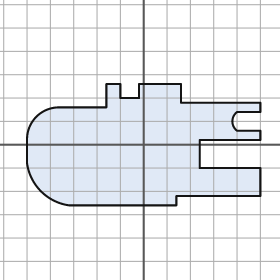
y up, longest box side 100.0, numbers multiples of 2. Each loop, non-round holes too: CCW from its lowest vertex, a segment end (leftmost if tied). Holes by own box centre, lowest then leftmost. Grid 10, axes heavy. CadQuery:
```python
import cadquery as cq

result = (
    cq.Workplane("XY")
    .moveTo(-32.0, -26.0)
    .lineTo(14.0, -26.0)
    .lineTo(14.0, -22.0)
    .lineTo(50.0, -22.0)
    .lineTo(50.0, -10.0)
    .lineTo(24.0, -10.0)
    .lineTo(24.0, 2.0)
    .lineTo(50.0, 2.0)
    .lineTo(50.0, 6.0)
    .lineTo(40.0, 6.0)
    .threePointArc((38.0, 10.0), (40.0, 14.0))
    .lineTo(50.0, 14.0)
    .lineTo(50.0, 18.0)
    .lineTo(16.0, 18.0)
    .lineTo(16.0, 26.0)
    .lineTo(-2.0, 26.0)
    .lineTo(-2.0, 20.0)
    .lineTo(-10.0, 20.0)
    .lineTo(-10.0, 26.0)
    .lineTo(-16.0, 26.0)
    .lineTo(-16.0, 16.0)
    .lineTo(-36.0, 16.0)
    .threePointArc((-46.0, 12.0), (-50.0, 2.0))
    .lineTo(-50.0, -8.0)
    .threePointArc((-44.0, -20.0), (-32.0, -26.0))
    .close()
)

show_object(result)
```